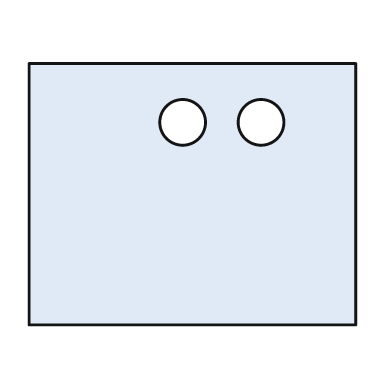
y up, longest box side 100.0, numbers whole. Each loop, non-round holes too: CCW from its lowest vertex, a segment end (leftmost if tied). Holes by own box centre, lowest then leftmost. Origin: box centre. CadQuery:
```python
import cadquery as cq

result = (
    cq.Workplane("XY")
    .moveTo(-50.0, -40.0)
    .lineTo(50.0, -40.0)
    .lineTo(50.0, 40.0)
    .lineTo(-50.0, 40.0)
    .close()
    .moveTo(-3.0, 22.0)
    .circle(7.0)
    .moveTo(21.0, 22.0)
    .circle(7.0)
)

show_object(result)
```